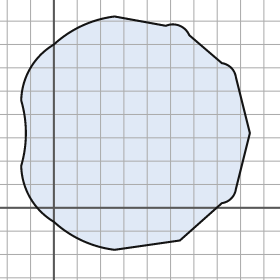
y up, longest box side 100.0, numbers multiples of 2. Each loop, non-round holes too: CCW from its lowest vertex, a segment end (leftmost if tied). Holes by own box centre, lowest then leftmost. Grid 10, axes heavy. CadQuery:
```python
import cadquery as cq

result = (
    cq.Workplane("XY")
    .moveTo(26.0, -18.0)
    .lineTo(54.0, -14.0)
    .lineTo(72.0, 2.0)
    .threePointArc((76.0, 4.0), (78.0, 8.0))
    .lineTo(84.0, 32.0)
    .lineTo(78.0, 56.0)
    .threePointArc((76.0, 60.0), (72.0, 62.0))
    .lineTo(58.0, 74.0)
    .threePointArc((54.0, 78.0), (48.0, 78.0))
    .lineTo(26.0, 82.0)
    .threePointArc((12.0, 78.0), (0.0, 70.0))
    .threePointArc((-10.0, 60.0), (-14.0, 46.0))
    .threePointArc((-12.0, 32.0), (-14.0, 18.0))
    .threePointArc((-10.0, 4.0), (0.0, -6.0))
    .threePointArc((12.0, -14.0), (26.0, -18.0))
    .close()
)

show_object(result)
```